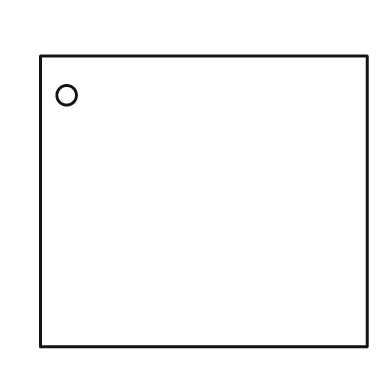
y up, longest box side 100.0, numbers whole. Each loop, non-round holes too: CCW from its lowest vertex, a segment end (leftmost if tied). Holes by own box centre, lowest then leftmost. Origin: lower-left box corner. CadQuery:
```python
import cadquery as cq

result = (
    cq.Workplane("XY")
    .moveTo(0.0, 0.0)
    .lineTo(100.0, 0.0)
    .lineTo(100.0, 89.0)
    .lineTo(0.0, 89.0)
    .close()
    .moveTo(8.0, 77.0)
    .circle(3.0)
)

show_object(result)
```